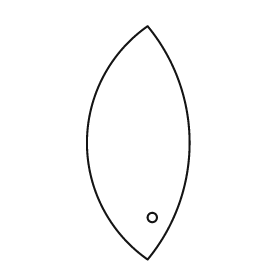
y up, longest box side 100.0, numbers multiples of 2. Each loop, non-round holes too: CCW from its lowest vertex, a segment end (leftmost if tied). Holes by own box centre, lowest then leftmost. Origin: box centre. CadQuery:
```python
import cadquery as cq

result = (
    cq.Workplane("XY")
    .moveTo(4.0, -50.0)
    .threePointArc((22.0, 0.0), (4.0, 50.0))
    .threePointArc((-22.0, 0.0), (4.0, -50.0))
    .close()
    .moveTo(6.0, -32.0)
    .circle(2.0)
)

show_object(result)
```